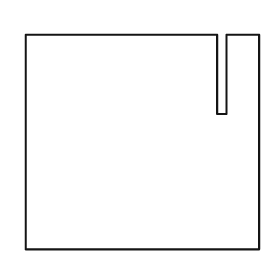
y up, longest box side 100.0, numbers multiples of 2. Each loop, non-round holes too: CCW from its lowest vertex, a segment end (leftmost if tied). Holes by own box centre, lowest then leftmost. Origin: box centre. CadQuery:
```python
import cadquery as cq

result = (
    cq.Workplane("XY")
    .moveTo(-50.0, -46.0)
    .lineTo(50.0, -46.0)
    .lineTo(50.0, 46.0)
    .lineTo(36.0, 46.0)
    .lineTo(36.0, 12.0)
    .lineTo(32.0, 12.0)
    .lineTo(32.0, 46.0)
    .lineTo(-50.0, 46.0)
    .close()
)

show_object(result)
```